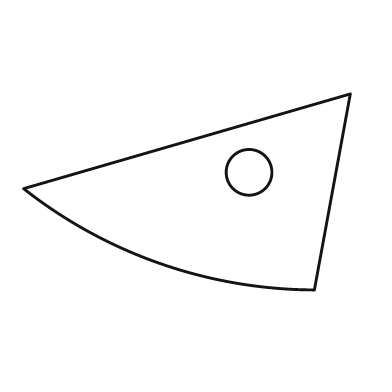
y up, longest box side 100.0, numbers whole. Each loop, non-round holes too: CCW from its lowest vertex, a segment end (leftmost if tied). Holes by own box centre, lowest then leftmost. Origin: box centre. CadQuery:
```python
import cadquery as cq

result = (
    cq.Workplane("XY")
    .moveTo(39.0, -30.0)
    .lineTo(50.0, 30.0)
    .lineTo(-50.0, 1.0)
    .threePointArc((-8.0, -22.0), (39.0, -30.0))
    .close()
    .moveTo(19.0, 6.0)
    .circle(7.0)
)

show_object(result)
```